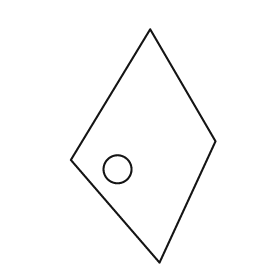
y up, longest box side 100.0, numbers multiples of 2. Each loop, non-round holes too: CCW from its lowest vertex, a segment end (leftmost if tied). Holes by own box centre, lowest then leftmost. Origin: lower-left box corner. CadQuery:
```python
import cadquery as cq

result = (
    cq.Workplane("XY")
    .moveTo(38.0, 0.0)
    .lineTo(62.0, 52.0)
    .lineTo(34.0, 100.0)
    .lineTo(0.0, 44.0)
    .close()
    .moveTo(20.0, 40.0)
    .circle(6.0)
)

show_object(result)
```